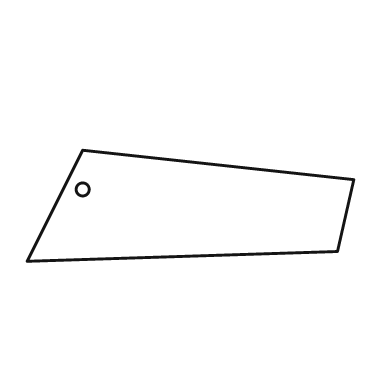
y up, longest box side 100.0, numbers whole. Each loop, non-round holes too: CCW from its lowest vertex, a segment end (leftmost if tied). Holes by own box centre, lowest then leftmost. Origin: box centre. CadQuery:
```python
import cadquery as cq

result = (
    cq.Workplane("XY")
    .moveTo(-50.0, -17.0)
    .lineTo(45.0, -14.0)
    .lineTo(50.0, 8.0)
    .lineTo(-33.0, 17.0)
    .close()
    .moveTo(-33.0, 5.0)
    .circle(2.0)
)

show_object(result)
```